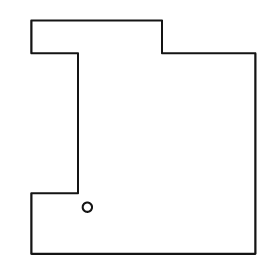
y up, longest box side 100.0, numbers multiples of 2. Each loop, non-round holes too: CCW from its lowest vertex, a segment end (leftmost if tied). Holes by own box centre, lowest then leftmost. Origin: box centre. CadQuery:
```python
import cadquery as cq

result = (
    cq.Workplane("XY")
    .moveTo(-48.0, -50.0)
    .lineTo(48.0, -50.0)
    .lineTo(48.0, 36.0)
    .lineTo(8.0, 36.0)
    .lineTo(8.0, 50.0)
    .lineTo(-48.0, 50.0)
    .lineTo(-48.0, 36.0)
    .lineTo(-28.0, 36.0)
    .lineTo(-28.0, -24.0)
    .lineTo(-48.0, -24.0)
    .close()
    .moveTo(-24.0, -30.0)
    .circle(2.0)
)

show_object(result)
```